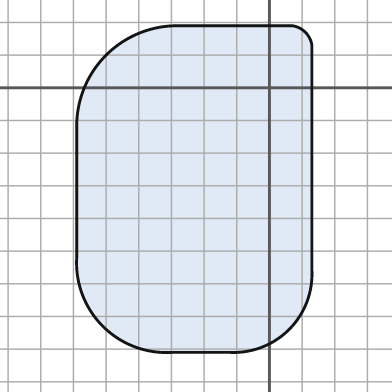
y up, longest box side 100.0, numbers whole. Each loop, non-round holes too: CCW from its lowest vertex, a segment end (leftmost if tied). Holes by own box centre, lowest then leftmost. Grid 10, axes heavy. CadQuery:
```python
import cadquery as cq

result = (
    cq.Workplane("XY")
    .moveTo(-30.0, -81.0)
    .lineTo(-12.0, -81.0)
    .threePointArc((6.0, -74.0), (13.0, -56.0))
    .lineTo(13.0, 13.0)
    .threePointArc((11.0, 17.0), (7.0, 19.0))
    .lineTo(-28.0, 19.0)
    .threePointArc((-50.0, 10.0), (-59.0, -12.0))
    .lineTo(-59.0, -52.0)
    .threePointArc((-51.0, -73.0), (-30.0, -81.0))
    .close()
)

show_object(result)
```